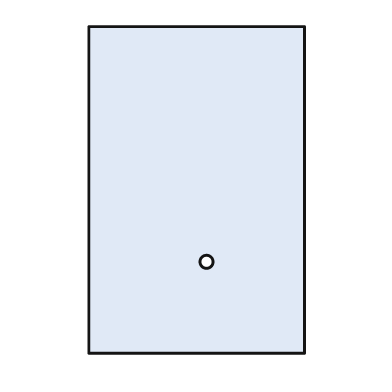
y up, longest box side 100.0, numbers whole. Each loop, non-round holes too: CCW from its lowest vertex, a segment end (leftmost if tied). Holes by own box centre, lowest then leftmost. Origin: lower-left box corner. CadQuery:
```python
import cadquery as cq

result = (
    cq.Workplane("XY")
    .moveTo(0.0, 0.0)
    .lineTo(66.0, 0.0)
    .lineTo(66.0, 100.0)
    .lineTo(0.0, 100.0)
    .close()
    .moveTo(36.0, 28.0)
    .circle(2.0)
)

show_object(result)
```